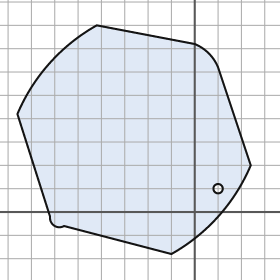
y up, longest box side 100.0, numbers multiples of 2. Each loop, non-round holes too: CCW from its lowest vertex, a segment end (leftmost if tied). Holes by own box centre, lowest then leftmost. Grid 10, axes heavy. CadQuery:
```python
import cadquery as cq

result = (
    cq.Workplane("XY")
    .moveTo(-10.0, -18.0)
    .threePointArc((10.0, -2.0), (24.0, 20.0))
    .lineTo(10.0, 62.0)
    .threePointArc((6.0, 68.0), (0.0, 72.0))
    .lineTo(-42.0, 80.0)
    .threePointArc((-62.0, 64.0), (-76.0, 42.0))
    .lineTo(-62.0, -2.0)
    .threePointArc((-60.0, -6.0), (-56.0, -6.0))
    .close()
    .moveTo(10.0, 10.0)
    .circle(2.0)
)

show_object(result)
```